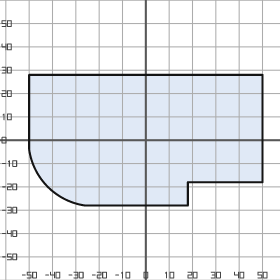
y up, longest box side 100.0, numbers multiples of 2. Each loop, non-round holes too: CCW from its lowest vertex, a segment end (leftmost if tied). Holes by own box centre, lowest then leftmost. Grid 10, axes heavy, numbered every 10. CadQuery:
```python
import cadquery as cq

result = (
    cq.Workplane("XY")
    .moveTo(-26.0, -28.0)
    .lineTo(18.0, -28.0)
    .lineTo(18.0, -18.0)
    .lineTo(50.0, -18.0)
    .lineTo(50.0, 28.0)
    .lineTo(-50.0, 28.0)
    .lineTo(-50.0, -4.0)
    .threePointArc((-42.0, -20.0), (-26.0, -28.0))
    .close()
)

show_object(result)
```